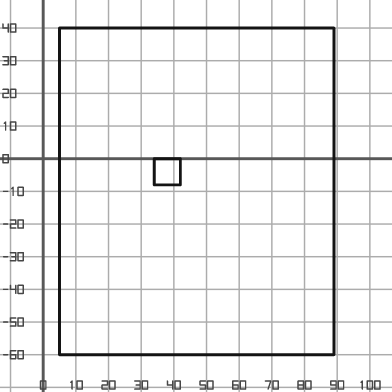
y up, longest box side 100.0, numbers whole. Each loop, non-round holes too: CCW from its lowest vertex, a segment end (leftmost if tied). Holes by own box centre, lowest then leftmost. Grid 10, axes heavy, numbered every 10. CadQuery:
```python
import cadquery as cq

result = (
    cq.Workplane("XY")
    .moveTo(5.0, -60.0)
    .lineTo(89.0, -60.0)
    .lineTo(89.0, 40.0)
    .lineTo(5.0, 40.0)
    .close()
    .moveTo(34.0, -8.0)
    .lineTo(42.0, -8.0)
    .lineTo(42.0, 0.0)
    .lineTo(34.0, 0.0)
    .close()
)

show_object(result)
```